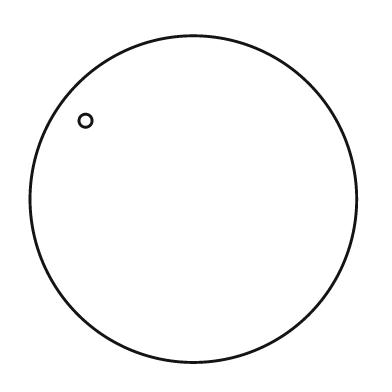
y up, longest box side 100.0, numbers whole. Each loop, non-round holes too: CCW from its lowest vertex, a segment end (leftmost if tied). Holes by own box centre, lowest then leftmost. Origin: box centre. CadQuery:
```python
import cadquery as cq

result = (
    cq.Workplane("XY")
    .moveTo(0.0, 0.0)
    .circle(50.0)
    .moveTo(-33.0, 24.0)
    .circle(2.0)
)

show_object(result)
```